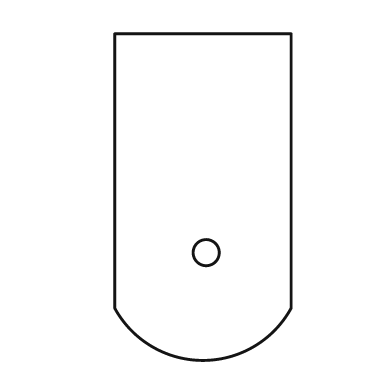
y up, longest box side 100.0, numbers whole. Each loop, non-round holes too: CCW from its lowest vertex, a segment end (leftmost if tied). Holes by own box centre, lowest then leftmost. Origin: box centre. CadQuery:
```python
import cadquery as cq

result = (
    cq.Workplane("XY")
    .moveTo(-27.0, -34.0)
    .threePointArc((0.0, -50.0), (27.0, -34.0))
    .lineTo(27.0, 50.0)
    .lineTo(-27.0, 50.0)
    .close()
    .moveTo(1.0, -17.0)
    .circle(4.0)
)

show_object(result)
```